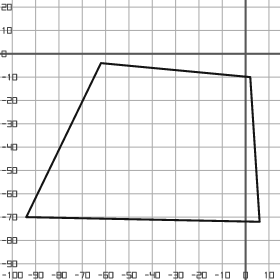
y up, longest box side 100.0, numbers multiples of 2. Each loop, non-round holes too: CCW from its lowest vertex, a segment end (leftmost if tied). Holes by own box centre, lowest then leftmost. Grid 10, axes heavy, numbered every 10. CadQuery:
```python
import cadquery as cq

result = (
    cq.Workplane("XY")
    .moveTo(6.0, -72.0)
    .lineTo(2.0, -10.0)
    .lineTo(-62.0, -4.0)
    .lineTo(-94.0, -70.0)
    .close()
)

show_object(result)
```